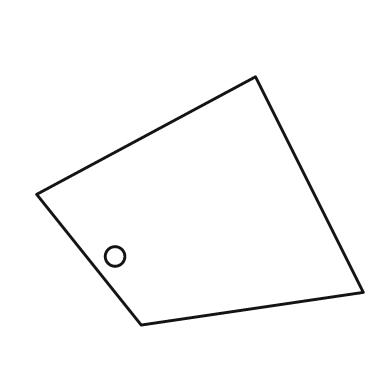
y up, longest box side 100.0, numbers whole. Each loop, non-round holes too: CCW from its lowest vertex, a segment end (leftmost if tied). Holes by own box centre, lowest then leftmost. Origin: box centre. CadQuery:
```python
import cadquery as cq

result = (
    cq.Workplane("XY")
    .moveTo(-18.0, -38.0)
    .lineTo(50.0, -28.0)
    .lineTo(17.0, 38.0)
    .lineTo(-50.0, 2.0)
    .close()
    .moveTo(-26.0, -17.0)
    .circle(3.0)
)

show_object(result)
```